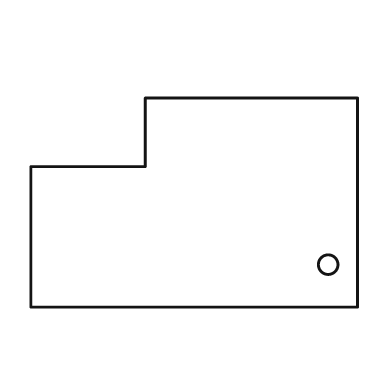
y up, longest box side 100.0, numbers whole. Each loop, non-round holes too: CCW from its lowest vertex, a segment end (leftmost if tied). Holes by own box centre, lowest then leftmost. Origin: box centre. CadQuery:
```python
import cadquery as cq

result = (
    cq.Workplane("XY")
    .moveTo(-50.0, -32.0)
    .lineTo(50.0, -32.0)
    .lineTo(50.0, 32.0)
    .lineTo(-15.0, 32.0)
    .lineTo(-15.0, 11.0)
    .lineTo(-50.0, 11.0)
    .close()
    .moveTo(41.0, -19.0)
    .circle(3.0)
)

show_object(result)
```